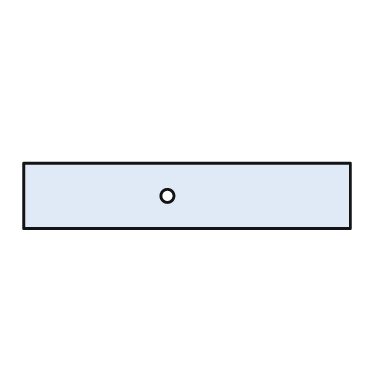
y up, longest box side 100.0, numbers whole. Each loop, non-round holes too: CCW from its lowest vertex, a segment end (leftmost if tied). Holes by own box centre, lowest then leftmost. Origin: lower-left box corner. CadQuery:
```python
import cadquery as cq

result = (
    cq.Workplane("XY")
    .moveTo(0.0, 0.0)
    .lineTo(100.0, 0.0)
    .lineTo(100.0, 20.0)
    .lineTo(0.0, 20.0)
    .close()
    .moveTo(44.0, 10.0)
    .circle(2.0)
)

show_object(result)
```